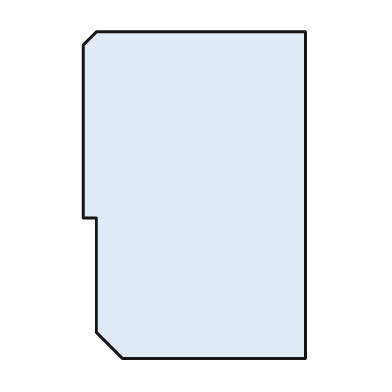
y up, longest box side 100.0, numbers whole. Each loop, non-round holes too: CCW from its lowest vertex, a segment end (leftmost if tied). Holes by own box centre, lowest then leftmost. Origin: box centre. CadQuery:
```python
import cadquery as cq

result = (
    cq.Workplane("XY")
    .moveTo(-22.0, -50.0)
    .lineTo(34.0, -50.0)
    .lineTo(34.0, 50.0)
    .lineTo(-30.0, 50.0)
    .lineTo(-34.0, 46.0)
    .lineTo(-34.0, -7.0)
    .lineTo(-30.0, -7.0)
    .lineTo(-30.0, -42.0)
    .close()
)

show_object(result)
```